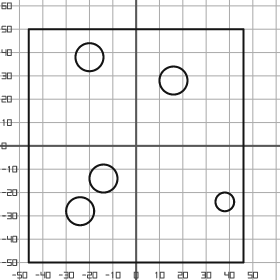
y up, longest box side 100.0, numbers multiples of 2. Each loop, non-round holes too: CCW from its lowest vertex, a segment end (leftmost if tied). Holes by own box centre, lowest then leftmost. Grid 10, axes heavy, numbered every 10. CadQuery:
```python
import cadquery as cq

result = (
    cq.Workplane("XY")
    .moveTo(-46.0, -50.0)
    .lineTo(46.0, -50.0)
    .lineTo(46.0, 50.0)
    .lineTo(-46.0, 50.0)
    .close()
    .moveTo(-24.0, -28.0)
    .circle(6.0)
    .moveTo(38.0, -24.0)
    .circle(4.0)
    .moveTo(-14.0, -14.0)
    .circle(6.0)
    .moveTo(16.0, 28.0)
    .circle(6.0)
    .moveTo(-20.0, 38.0)
    .circle(6.0)
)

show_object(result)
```